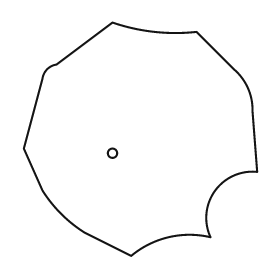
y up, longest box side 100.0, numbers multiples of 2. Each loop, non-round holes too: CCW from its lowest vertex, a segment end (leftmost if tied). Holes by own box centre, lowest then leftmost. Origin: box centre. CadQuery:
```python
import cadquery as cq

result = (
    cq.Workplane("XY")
    .moveTo(-4.0, -50.0)
    .threePointArc((12.0, -42.0), (30.0, -42.0))
    .threePointArc((32.0, -22.0), (50.0, -14.0))
    .lineTo(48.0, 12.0)
    .threePointArc((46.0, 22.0), (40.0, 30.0))
    .lineTo(24.0, 46.0)
    .threePointArc((6.0, 46.0), (-12.0, 50.0))
    .lineTo(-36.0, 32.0)
    .threePointArc((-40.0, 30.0), (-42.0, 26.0))
    .lineTo(-50.0, -4.0)
    .lineTo(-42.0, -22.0)
    .threePointArc((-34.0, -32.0), (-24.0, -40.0))
    .close()
    .moveTo(-12.0, -6.0)
    .circle(2.0)
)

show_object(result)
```